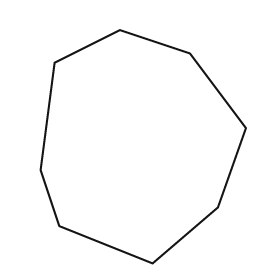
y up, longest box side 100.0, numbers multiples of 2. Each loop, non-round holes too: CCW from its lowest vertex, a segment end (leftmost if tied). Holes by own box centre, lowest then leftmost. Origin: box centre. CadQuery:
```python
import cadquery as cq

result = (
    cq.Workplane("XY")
    .moveTo(4.0, -50.0)
    .lineTo(32.0, -26.0)
    .lineTo(44.0, 8.0)
    .lineTo(20.0, 40.0)
    .lineTo(-10.0, 50.0)
    .lineTo(-38.0, 36.0)
    .lineTo(-44.0, -10.0)
    .lineTo(-36.0, -34.0)
    .close()
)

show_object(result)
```